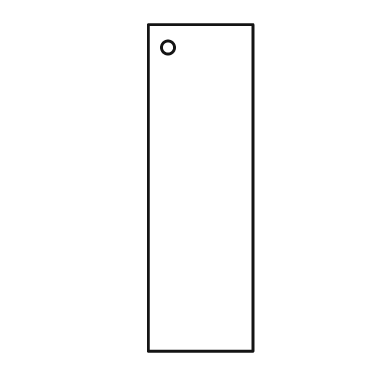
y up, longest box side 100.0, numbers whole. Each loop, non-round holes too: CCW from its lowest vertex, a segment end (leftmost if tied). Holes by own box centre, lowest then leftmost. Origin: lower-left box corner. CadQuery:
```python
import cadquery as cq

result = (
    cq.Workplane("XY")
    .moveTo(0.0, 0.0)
    .lineTo(32.0, 0.0)
    .lineTo(32.0, 100.0)
    .lineTo(0.0, 100.0)
    .close()
    .moveTo(6.0, 93.0)
    .circle(2.0)
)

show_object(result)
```